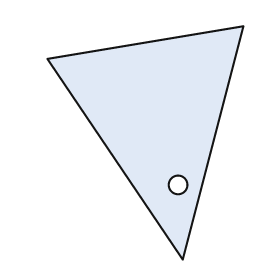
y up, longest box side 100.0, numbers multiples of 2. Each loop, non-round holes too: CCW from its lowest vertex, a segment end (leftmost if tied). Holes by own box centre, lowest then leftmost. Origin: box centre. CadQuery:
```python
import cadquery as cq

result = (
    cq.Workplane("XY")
    .moveTo(16.0, -50.0)
    .lineTo(42.0, 50.0)
    .lineTo(-42.0, 36.0)
    .close()
    .moveTo(14.0, -18.0)
    .circle(4.0)
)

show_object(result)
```